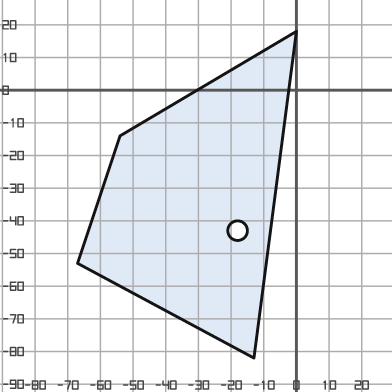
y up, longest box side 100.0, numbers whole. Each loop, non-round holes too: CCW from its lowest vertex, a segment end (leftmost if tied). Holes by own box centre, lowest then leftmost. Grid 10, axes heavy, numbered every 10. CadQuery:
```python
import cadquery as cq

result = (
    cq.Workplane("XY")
    .moveTo(-13.0, -82.0)
    .lineTo(0.0, 18.0)
    .lineTo(-54.0, -14.0)
    .lineTo(-67.0, -53.0)
    .close()
    .moveTo(-18.0, -43.0)
    .circle(3.0)
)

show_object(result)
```